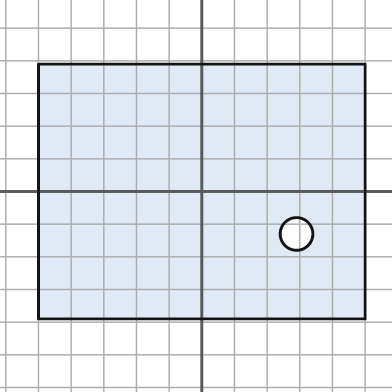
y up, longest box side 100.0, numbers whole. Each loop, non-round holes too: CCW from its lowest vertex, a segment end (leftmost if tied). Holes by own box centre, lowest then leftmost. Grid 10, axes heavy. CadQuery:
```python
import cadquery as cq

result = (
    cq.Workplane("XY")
    .moveTo(-50.0, -39.0)
    .lineTo(50.0, -39.0)
    .lineTo(50.0, 39.0)
    .lineTo(-50.0, 39.0)
    .close()
    .moveTo(29.0, -13.0)
    .circle(5.0)
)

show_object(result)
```